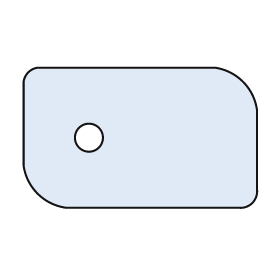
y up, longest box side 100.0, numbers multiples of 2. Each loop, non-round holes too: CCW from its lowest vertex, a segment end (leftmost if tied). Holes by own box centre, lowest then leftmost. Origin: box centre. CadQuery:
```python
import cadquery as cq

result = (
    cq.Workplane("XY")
    .moveTo(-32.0, -30.0)
    .lineTo(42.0, -30.0)
    .threePointArc((48.0, -28.0), (50.0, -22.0))
    .lineTo(50.0, 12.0)
    .threePointArc((44.0, 24.0), (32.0, 30.0))
    .lineTo(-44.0, 30.0)
    .threePointArc((-48.0, 28.0), (-50.0, 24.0))
    .lineTo(-50.0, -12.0)
    .threePointArc((-44.0, -24.0), (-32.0, -30.0))
    .close()
    .moveTo(-22.0, 0.0)
    .circle(6.0)
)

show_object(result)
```